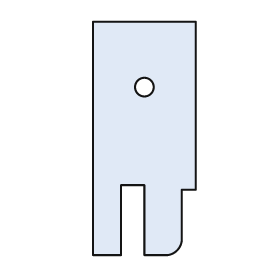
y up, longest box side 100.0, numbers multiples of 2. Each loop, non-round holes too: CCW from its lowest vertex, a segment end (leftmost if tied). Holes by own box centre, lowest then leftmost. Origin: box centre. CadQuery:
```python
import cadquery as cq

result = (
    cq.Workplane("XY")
    .moveTo(-22.0, -50.0)
    .lineTo(-10.0, -50.0)
    .lineTo(-10.0, -20.0)
    .lineTo(0.0, -20.0)
    .lineTo(0.0, -50.0)
    .lineTo(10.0, -50.0)
    .threePointArc((14.0, -48.0), (16.0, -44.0))
    .lineTo(16.0, -22.0)
    .lineTo(22.0, -22.0)
    .lineTo(22.0, 50.0)
    .lineTo(-22.0, 50.0)
    .close()
    .moveTo(0.0, 22.0)
    .circle(4.0)
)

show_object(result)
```